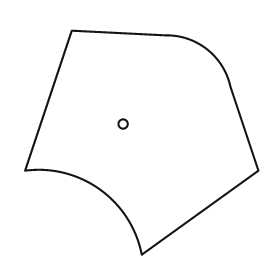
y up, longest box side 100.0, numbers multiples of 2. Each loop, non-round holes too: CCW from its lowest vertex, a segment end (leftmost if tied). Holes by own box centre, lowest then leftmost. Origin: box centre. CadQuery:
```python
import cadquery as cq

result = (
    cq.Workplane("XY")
    .moveTo(0.0, -48.0)
    .lineTo(50.0, -12.0)
    .lineTo(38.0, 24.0)
    .threePointArc((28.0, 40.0), (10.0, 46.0))
    .lineTo(-30.0, 48.0)
    .lineTo(-50.0, -12.0)
    .threePointArc((-18.0, -20.0), (0.0, -48.0))
    .close()
    .moveTo(-8.0, 8.0)
    .circle(2.0)
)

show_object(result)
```